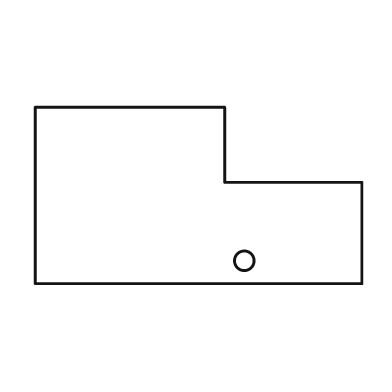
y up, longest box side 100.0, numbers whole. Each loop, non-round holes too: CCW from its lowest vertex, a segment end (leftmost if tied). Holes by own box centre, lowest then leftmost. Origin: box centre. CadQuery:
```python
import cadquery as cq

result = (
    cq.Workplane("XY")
    .moveTo(-50.0, -27.0)
    .lineTo(50.0, -27.0)
    .lineTo(50.0, 4.0)
    .lineTo(8.0, 4.0)
    .lineTo(8.0, 27.0)
    .lineTo(-50.0, 27.0)
    .close()
    .moveTo(14.0, -20.0)
    .circle(3.0)
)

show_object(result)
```